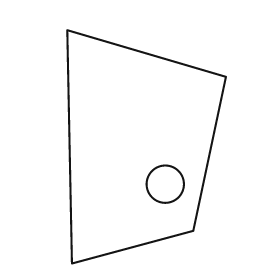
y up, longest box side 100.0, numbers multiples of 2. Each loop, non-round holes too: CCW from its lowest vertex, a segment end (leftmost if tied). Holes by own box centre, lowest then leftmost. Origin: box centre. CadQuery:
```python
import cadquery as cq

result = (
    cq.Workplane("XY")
    .moveTo(-32.0, -50.0)
    .lineTo(20.0, -36.0)
    .lineTo(34.0, 30.0)
    .lineTo(-34.0, 50.0)
    .close()
    .moveTo(8.0, -16.0)
    .circle(8.0)
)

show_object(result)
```